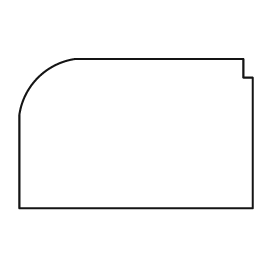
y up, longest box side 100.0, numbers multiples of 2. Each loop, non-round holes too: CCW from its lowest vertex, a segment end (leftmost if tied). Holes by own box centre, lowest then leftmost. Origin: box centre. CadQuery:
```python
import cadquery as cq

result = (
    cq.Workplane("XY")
    .moveTo(-50.0, -32.0)
    .lineTo(50.0, -32.0)
    .lineTo(50.0, 24.0)
    .lineTo(46.0, 24.0)
    .lineTo(46.0, 32.0)
    .lineTo(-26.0, 32.0)
    .threePointArc((-42.0, 24.0), (-50.0, 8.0))
    .close()
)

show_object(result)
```